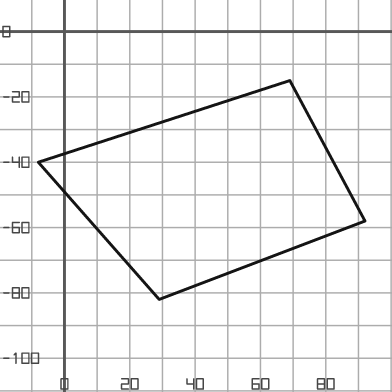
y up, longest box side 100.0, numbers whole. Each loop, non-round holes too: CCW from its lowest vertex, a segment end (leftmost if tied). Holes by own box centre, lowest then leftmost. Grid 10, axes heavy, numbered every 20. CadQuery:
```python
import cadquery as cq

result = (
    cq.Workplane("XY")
    .moveTo(29.0, -82.0)
    .lineTo(92.0, -58.0)
    .lineTo(69.0, -15.0)
    .lineTo(-8.0, -40.0)
    .close()
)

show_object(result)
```